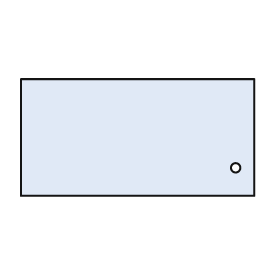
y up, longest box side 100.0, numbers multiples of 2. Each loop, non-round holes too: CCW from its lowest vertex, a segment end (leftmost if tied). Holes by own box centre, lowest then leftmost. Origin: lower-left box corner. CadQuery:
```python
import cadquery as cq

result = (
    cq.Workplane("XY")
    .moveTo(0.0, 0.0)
    .lineTo(100.0, 0.0)
    .lineTo(100.0, 50.0)
    .lineTo(0.0, 50.0)
    .close()
    .moveTo(92.0, 12.0)
    .circle(2.0)
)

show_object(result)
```